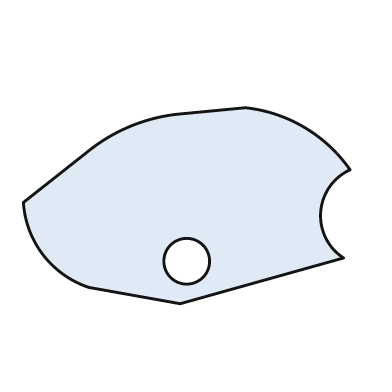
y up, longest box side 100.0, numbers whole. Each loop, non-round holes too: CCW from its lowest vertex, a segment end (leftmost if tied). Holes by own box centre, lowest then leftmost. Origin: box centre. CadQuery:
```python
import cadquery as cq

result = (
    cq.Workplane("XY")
    .moveTo(-2.0, -30.0)
    .lineTo(48.0, -16.0)
    .threePointArc((41.0, -2.0), (50.0, 11.0))
    .threePointArc((36.0, 24.0), (18.0, 30.0))
    .lineTo(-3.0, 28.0)
    .threePointArc((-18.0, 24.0), (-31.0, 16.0))
    .lineTo(-50.0, 1.0)
    .threePointArc((-44.0, -15.0), (-30.0, -25.0))
    .close()
    .moveTo(0.0, -17.0)
    .circle(7.0)
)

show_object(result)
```